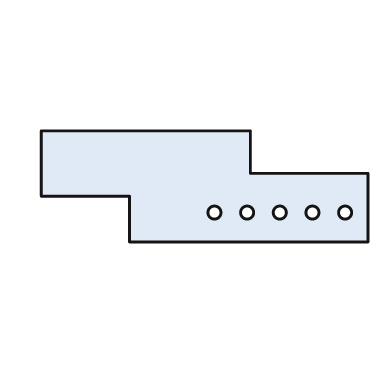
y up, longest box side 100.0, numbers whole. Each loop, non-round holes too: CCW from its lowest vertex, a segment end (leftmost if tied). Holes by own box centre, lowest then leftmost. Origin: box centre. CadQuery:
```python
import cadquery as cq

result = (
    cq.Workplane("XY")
    .moveTo(-23.0, -17.0)
    .lineTo(50.0, -17.0)
    .lineTo(50.0, 4.0)
    .lineTo(14.0, 4.0)
    .lineTo(14.0, 17.0)
    .lineTo(-50.0, 17.0)
    .lineTo(-50.0, -3.0)
    .lineTo(-23.0, -3.0)
    .close()
    .moveTo(3.0, -8.0)
    .circle(2.0)
    .moveTo(13.0, -8.0)
    .circle(2.0)
    .moveTo(23.0, -8.0)
    .circle(2.0)
    .moveTo(33.0, -8.0)
    .circle(2.0)
    .moveTo(43.0, -8.0)
    .circle(2.0)
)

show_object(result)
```